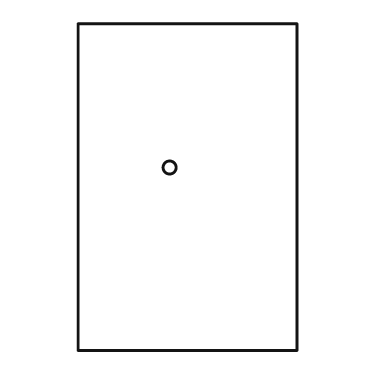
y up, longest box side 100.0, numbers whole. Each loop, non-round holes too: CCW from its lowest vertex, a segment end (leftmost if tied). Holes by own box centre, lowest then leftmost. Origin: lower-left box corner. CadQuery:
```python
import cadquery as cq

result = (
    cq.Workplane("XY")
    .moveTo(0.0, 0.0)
    .lineTo(67.0, 0.0)
    .lineTo(67.0, 100.0)
    .lineTo(0.0, 100.0)
    .close()
    .moveTo(28.0, 56.0)
    .circle(2.0)
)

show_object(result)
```